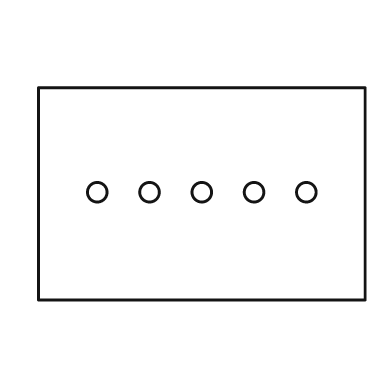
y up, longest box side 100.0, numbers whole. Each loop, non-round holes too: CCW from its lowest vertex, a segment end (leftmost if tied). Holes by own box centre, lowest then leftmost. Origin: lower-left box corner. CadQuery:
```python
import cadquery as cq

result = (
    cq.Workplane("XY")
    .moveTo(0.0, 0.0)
    .lineTo(100.0, 0.0)
    .lineTo(100.0, 65.0)
    .lineTo(0.0, 65.0)
    .close()
    .moveTo(18.0, 33.0)
    .circle(3.0)
    .moveTo(34.0, 33.0)
    .circle(3.0)
    .moveTo(50.0, 33.0)
    .circle(3.0)
    .moveTo(66.0, 33.0)
    .circle(3.0)
    .moveTo(82.0, 33.0)
    .circle(3.0)
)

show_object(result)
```